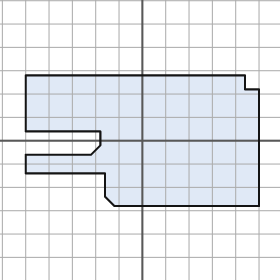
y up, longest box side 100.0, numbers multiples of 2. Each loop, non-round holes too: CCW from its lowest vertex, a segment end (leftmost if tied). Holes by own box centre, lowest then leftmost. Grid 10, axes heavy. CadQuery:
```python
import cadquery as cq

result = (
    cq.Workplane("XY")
    .moveTo(-12.0, -28.0)
    .lineTo(50.0, -28.0)
    .lineTo(50.0, 22.0)
    .lineTo(44.0, 22.0)
    .lineTo(44.0, 28.0)
    .lineTo(-50.0, 28.0)
    .lineTo(-50.0, 4.0)
    .lineTo(-18.0, 4.0)
    .lineTo(-18.0, -2.0)
    .lineTo(-22.0, -6.0)
    .lineTo(-50.0, -6.0)
    .lineTo(-50.0, -14.0)
    .lineTo(-16.0, -14.0)
    .lineTo(-16.0, -24.0)
    .close()
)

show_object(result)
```